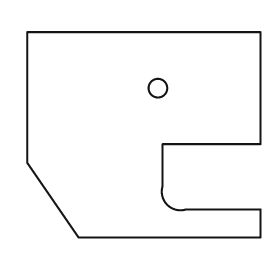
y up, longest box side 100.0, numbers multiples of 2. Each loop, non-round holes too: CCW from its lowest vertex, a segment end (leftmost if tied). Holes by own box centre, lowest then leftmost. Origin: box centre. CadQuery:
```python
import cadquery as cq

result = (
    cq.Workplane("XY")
    .moveTo(-28.0, -44.0)
    .lineTo(50.0, -44.0)
    .lineTo(50.0, -32.0)
    .lineTo(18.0, -32.0)
    .threePointArc((10.0, -30.0), (8.0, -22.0))
    .lineTo(8.0, -4.0)
    .lineTo(50.0, -4.0)
    .lineTo(50.0, 44.0)
    .lineTo(-50.0, 44.0)
    .lineTo(-50.0, -12.0)
    .close()
    .moveTo(6.0, 20.0)
    .circle(4.0)
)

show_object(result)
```